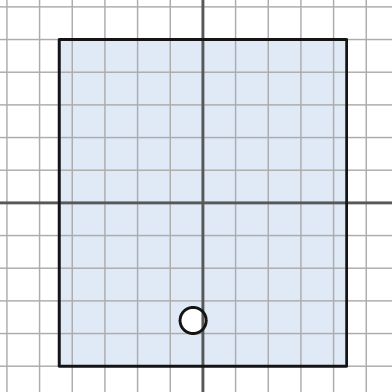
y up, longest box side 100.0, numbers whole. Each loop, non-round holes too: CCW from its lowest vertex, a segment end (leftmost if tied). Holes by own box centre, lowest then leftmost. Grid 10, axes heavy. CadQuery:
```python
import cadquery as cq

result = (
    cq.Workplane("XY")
    .moveTo(-44.0, -50.0)
    .lineTo(44.0, -50.0)
    .lineTo(44.0, 50.0)
    .lineTo(-44.0, 50.0)
    .close()
    .moveTo(-3.0, -36.0)
    .circle(4.0)
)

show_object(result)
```